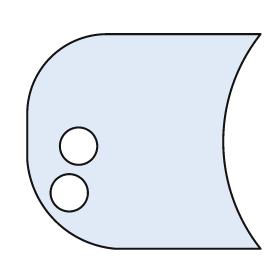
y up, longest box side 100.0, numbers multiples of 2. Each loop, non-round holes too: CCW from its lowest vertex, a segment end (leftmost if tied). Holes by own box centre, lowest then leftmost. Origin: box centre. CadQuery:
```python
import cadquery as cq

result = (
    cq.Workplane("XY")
    .moveTo(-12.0, -46.0)
    .lineTo(50.0, -46.0)
    .threePointArc((34.0, 0.0), (50.0, 46.0))
    .lineTo(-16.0, 46.0)
    .threePointArc((-40.0, 36.0), (-50.0, 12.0))
    .lineTo(-50.0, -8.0)
    .threePointArc((-38.0, -34.0), (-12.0, -46.0))
    .close()
    .moveTo(-32.0, -22.0)
    .circle(8.0)
    .moveTo(-28.0, -2.0)
    .circle(8.0)
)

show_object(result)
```